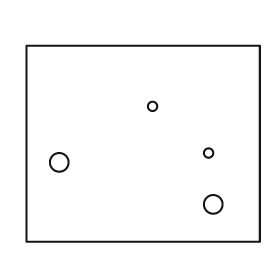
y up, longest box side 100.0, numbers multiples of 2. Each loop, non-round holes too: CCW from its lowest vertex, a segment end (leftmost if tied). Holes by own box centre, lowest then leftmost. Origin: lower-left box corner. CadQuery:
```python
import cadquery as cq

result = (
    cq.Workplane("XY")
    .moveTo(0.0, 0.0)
    .lineTo(100.0, 0.0)
    .lineTo(100.0, 84.0)
    .lineTo(0.0, 84.0)
    .close()
    .moveTo(80.0, 16.0)
    .circle(4.0)
    .moveTo(14.0, 34.0)
    .circle(4.0)
    .moveTo(78.0, 38.0)
    .circle(2.0)
    .moveTo(54.0, 58.0)
    .circle(2.0)
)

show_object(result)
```